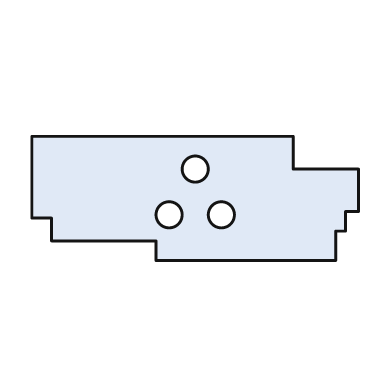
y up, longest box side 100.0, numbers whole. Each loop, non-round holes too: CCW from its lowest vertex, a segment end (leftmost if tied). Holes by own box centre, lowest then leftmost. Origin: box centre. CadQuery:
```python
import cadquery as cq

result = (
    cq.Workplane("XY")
    .moveTo(-12.0, -19.0)
    .lineTo(43.0, -19.0)
    .lineTo(43.0, -10.0)
    .lineTo(46.0, -10.0)
    .lineTo(46.0, -4.0)
    .lineTo(50.0, -4.0)
    .lineTo(50.0, 9.0)
    .lineTo(30.0, 9.0)
    .lineTo(30.0, 19.0)
    .lineTo(-50.0, 19.0)
    .lineTo(-50.0, -6.0)
    .lineTo(-44.0, -6.0)
    .lineTo(-44.0, -13.0)
    .lineTo(-12.0, -13.0)
    .close()
    .moveTo(-8.0, -5.0)
    .circle(4.0)
    .moveTo(8.0, -5.0)
    .circle(4.0)
    .moveTo(0.0, 9.0)
    .circle(4.0)
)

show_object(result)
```